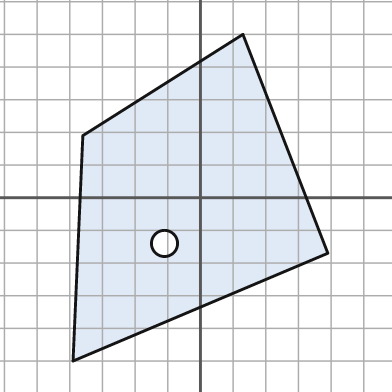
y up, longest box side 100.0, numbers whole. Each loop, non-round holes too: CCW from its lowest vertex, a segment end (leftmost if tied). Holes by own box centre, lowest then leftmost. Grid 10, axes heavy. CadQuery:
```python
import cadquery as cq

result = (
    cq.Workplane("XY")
    .moveTo(-39.0, -50.0)
    .lineTo(39.0, -17.0)
    .lineTo(13.0, 50.0)
    .lineTo(-36.0, 19.0)
    .close()
    .moveTo(-11.0, -14.0)
    .circle(4.0)
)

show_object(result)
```